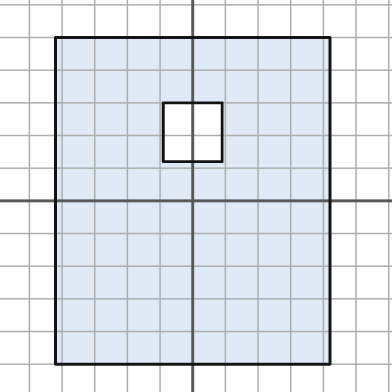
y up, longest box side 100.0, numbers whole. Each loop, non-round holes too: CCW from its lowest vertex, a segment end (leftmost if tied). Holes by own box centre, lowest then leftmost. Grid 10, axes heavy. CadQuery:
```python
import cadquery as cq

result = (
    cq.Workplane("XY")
    .moveTo(-42.0, -50.0)
    .lineTo(42.0, -50.0)
    .lineTo(42.0, 50.0)
    .lineTo(-42.0, 50.0)
    .close()
    .moveTo(-9.0, 12.0)
    .lineTo(9.0, 12.0)
    .lineTo(9.0, 30.0)
    .lineTo(-9.0, 30.0)
    .close()
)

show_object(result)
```